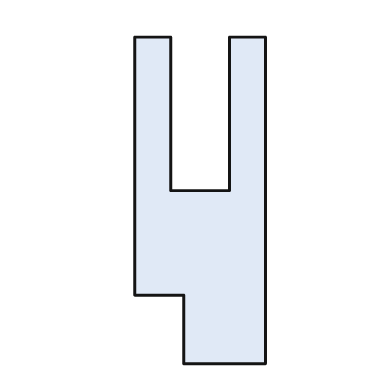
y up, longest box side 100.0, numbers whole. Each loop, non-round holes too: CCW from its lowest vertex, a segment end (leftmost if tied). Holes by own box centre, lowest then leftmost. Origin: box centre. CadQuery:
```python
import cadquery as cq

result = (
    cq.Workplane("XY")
    .moveTo(-5.0, -50.0)
    .lineTo(20.0, -50.0)
    .lineTo(20.0, 50.0)
    .lineTo(9.0, 50.0)
    .lineTo(9.0, 3.0)
    .lineTo(-9.0, 3.0)
    .lineTo(-9.0, 50.0)
    .lineTo(-20.0, 50.0)
    .lineTo(-20.0, -29.0)
    .lineTo(-5.0, -29.0)
    .close()
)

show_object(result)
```